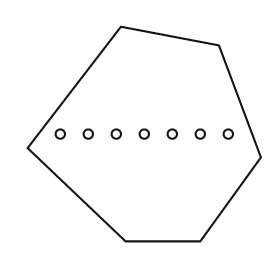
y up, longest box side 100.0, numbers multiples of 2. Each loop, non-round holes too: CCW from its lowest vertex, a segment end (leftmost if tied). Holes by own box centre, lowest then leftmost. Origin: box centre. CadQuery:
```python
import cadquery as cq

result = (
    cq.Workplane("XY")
    .moveTo(-8.0, -46.0)
    .lineTo(24.0, -46.0)
    .lineTo(50.0, -10.0)
    .lineTo(32.0, 38.0)
    .lineTo(-10.0, 46.0)
    .lineTo(-50.0, -6.0)
    .close()
    .moveTo(-36.0, 0.0)
    .circle(2.0)
    .moveTo(-24.0, 0.0)
    .circle(2.0)
    .moveTo(-12.0, 0.0)
    .circle(2.0)
    .moveTo(0.0, 0.0)
    .circle(2.0)
    .moveTo(12.0, 0.0)
    .circle(2.0)
    .moveTo(24.0, 0.0)
    .circle(2.0)
    .moveTo(36.0, 0.0)
    .circle(2.0)
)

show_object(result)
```